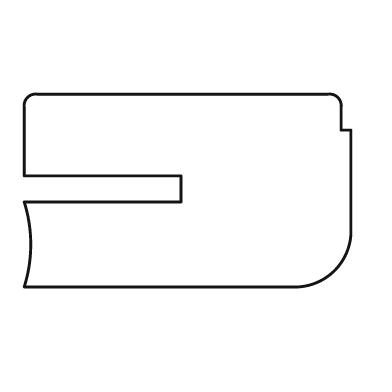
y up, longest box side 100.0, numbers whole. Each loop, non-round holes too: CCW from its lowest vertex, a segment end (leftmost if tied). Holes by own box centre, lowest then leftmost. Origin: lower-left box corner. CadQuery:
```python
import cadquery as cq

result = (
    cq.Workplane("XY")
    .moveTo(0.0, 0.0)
    .lineTo(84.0, 0.0)
    .threePointArc((95.0, 5.0), (100.0, 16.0))
    .lineTo(100.0, 48.0)
    .lineTo(97.0, 48.0)
    .lineTo(97.0, 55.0)
    .threePointArc((96.0, 58.0), (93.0, 59.0))
    .lineTo(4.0, 59.0)
    .threePointArc((1.0, 58.0), (0.0, 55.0))
    .lineTo(0.0, 34.0)
    .lineTo(48.0, 34.0)
    .lineTo(48.0, 26.0)
    .lineTo(0.0, 26.0)
    .threePointArc((2.0, 13.0), (0.0, 0.0))
    .close()
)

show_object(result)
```